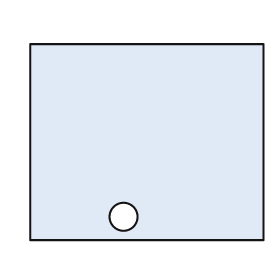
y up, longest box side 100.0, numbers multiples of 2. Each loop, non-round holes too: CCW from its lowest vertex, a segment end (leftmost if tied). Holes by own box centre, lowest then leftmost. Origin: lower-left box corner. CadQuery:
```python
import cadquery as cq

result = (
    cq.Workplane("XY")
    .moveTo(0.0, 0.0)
    .lineTo(100.0, 0.0)
    .lineTo(100.0, 84.0)
    .lineTo(0.0, 84.0)
    .close()
    .moveTo(40.0, 10.0)
    .circle(6.0)
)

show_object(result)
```